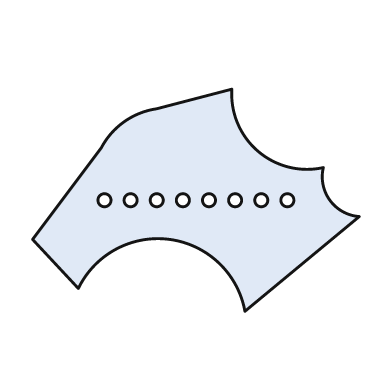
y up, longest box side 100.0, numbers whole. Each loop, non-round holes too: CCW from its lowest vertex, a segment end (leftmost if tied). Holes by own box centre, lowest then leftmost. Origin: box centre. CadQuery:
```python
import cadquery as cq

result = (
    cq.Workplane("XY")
    .moveTo(15.0, -34.0)
    .lineTo(50.0, -5.0)
    .threePointArc((41.0, 0.0), (39.0, 10.0))
    .threePointArc((19.0, 15.0), (11.0, 34.0))
    .lineTo(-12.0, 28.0)
    .threePointArc((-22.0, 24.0), (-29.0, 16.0))
    .lineTo(-50.0, -12.0)
    .lineTo(-36.0, -27.0)
    .threePointArc((-8.0, -12.0), (15.0, -34.0))
    .close()
    .moveTo(-28.0, 0.0)
    .circle(2.0)
    .moveTo(-20.0, 0.0)
    .circle(2.0)
    .moveTo(-12.0, 0.0)
    .circle(2.0)
    .moveTo(-4.0, 0.0)
    .circle(2.0)
    .moveTo(4.0, 0.0)
    .circle(2.0)
    .moveTo(12.0, 0.0)
    .circle(2.0)
    .moveTo(20.0, 0.0)
    .circle(2.0)
    .moveTo(28.0, 0.0)
    .circle(2.0)
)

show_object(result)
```